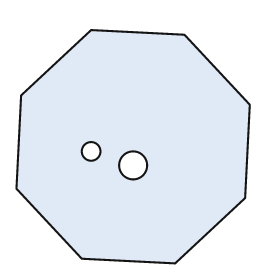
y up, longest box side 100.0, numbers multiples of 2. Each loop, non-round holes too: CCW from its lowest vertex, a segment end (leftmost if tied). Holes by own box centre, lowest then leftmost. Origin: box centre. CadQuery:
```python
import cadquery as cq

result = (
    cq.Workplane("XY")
    .moveTo(18.0, -50.0)
    .lineTo(48.0, -22.0)
    .lineTo(50.0, 18.0)
    .lineTo(22.0, 48.0)
    .lineTo(-18.0, 50.0)
    .lineTo(-48.0, 22.0)
    .lineTo(-50.0, -18.0)
    .lineTo(-22.0, -48.0)
    .close()
    .moveTo(0.0, -8.0)
    .circle(6.0)
    .moveTo(-18.0, -2.0)
    .circle(4.0)
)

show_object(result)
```